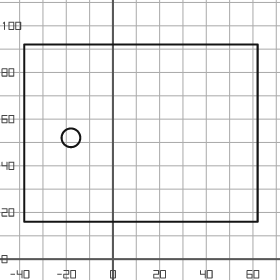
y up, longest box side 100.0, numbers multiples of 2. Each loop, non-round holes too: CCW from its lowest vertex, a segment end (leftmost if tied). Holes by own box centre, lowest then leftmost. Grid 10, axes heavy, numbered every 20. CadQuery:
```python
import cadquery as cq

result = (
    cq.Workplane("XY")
    .moveTo(-38.0, 16.0)
    .lineTo(62.0, 16.0)
    .lineTo(62.0, 92.0)
    .lineTo(-38.0, 92.0)
    .close()
    .moveTo(-18.0, 52.0)
    .circle(4.0)
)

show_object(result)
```